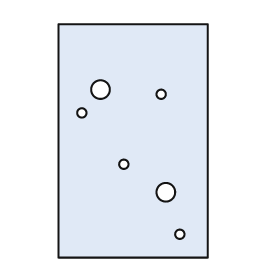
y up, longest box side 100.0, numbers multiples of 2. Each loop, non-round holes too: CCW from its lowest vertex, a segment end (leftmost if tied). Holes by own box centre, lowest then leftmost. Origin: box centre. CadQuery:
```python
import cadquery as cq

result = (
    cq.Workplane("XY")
    .moveTo(-32.0, -50.0)
    .lineTo(32.0, -50.0)
    .lineTo(32.0, 50.0)
    .lineTo(-32.0, 50.0)
    .close()
    .moveTo(20.0, -40.0)
    .circle(2.0)
    .moveTo(14.0, -22.0)
    .circle(4.0)
    .moveTo(-4.0, -10.0)
    .circle(2.0)
    .moveTo(-22.0, 12.0)
    .circle(2.0)
    .moveTo(12.0, 20.0)
    .circle(2.0)
    .moveTo(-14.0, 22.0)
    .circle(4.0)
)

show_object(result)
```